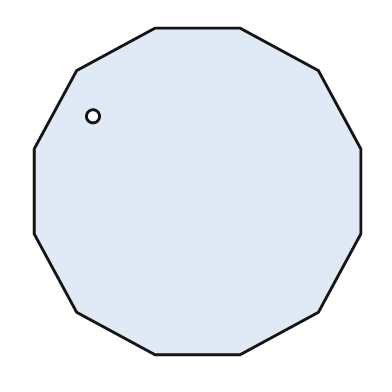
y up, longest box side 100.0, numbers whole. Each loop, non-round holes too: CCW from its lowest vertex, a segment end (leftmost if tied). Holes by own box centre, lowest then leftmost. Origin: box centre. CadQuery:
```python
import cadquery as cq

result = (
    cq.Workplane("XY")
    .moveTo(-13.0, -50.0)
    .lineTo(13.0, -50.0)
    .lineTo(37.0, -37.0)
    .lineTo(50.0, -13.0)
    .lineTo(50.0, 13.0)
    .lineTo(37.0, 37.0)
    .lineTo(13.0, 50.0)
    .lineTo(-13.0, 50.0)
    .lineTo(-37.0, 37.0)
    .lineTo(-50.0, 13.0)
    .lineTo(-50.0, -13.0)
    .lineTo(-37.0, -37.0)
    .close()
    .moveTo(-32.0, 23.0)
    .circle(2.0)
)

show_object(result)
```